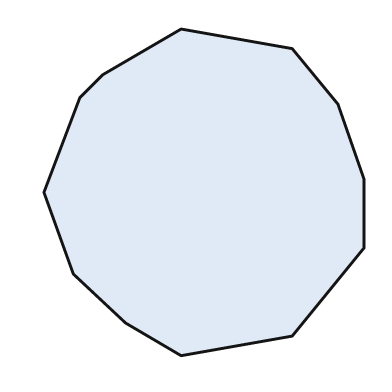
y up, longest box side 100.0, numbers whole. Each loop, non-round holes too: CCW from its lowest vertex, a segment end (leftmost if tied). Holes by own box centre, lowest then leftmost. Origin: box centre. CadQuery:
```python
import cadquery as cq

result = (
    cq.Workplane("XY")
    .moveTo(-7.0, -50.0)
    .lineTo(27.0, -44.0)
    .lineTo(49.0, -17.0)
    .lineTo(49.0, 4.0)
    .lineTo(41.0, 27.0)
    .lineTo(27.0, 44.0)
    .lineTo(-7.0, 50.0)
    .lineTo(-31.0, 36.0)
    .lineTo(-38.0, 29.0)
    .lineTo(-49.0, 0.0)
    .lineTo(-40.0, -25.0)
    .lineTo(-24.0, -40.0)
    .close()
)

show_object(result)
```